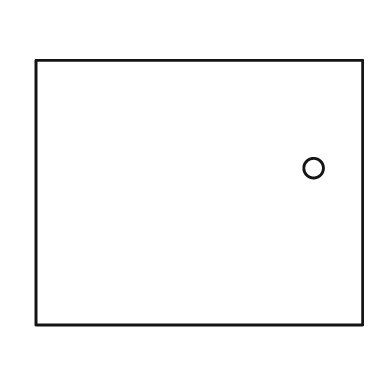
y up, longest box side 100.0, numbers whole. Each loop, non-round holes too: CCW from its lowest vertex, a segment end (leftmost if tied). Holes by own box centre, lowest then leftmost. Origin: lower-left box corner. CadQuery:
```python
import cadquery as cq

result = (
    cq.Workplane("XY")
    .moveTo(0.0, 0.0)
    .lineTo(100.0, 0.0)
    .lineTo(100.0, 81.0)
    .lineTo(0.0, 81.0)
    .close()
    .moveTo(85.0, 48.0)
    .circle(3.0)
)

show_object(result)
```